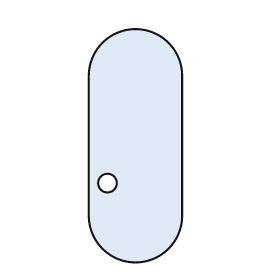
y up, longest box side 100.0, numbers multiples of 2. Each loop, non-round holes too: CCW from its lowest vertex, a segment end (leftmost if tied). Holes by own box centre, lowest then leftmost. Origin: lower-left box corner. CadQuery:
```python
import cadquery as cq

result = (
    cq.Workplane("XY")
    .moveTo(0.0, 20.0)
    .threePointArc((20.0, 0.0), (40.0, 20.0))
    .lineTo(40.0, 80.0)
    .threePointArc((20.0, 100.0), (0.0, 80.0))
    .close()
    .moveTo(8.0, 34.0)
    .circle(4.0)
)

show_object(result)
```